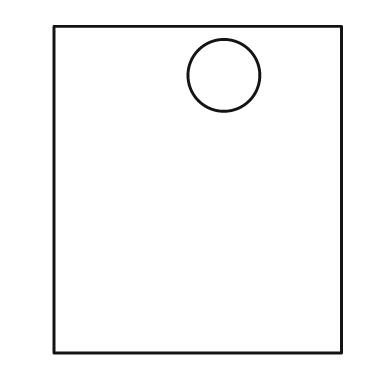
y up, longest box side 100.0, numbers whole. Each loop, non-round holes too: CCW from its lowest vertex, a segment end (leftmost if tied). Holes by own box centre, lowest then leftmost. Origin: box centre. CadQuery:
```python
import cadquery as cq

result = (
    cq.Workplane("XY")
    .moveTo(-44.0, -50.0)
    .lineTo(44.0, -50.0)
    .lineTo(44.0, 50.0)
    .lineTo(-44.0, 50.0)
    .close()
    .moveTo(8.0, 35.0)
    .circle(11.0)
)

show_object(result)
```